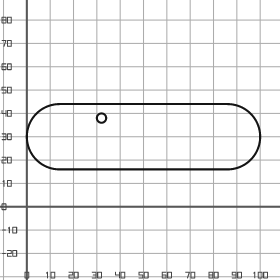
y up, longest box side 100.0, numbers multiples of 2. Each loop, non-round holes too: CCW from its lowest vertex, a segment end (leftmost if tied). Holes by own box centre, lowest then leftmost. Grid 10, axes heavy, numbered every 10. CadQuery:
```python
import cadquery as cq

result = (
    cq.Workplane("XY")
    .moveTo(14.0, 16.0)
    .lineTo(86.0, 16.0)
    .threePointArc((100.0, 30.0), (86.0, 44.0))
    .lineTo(14.0, 44.0)
    .threePointArc((0.0, 30.0), (14.0, 16.0))
    .close()
    .moveTo(32.0, 38.0)
    .circle(2.0)
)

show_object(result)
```